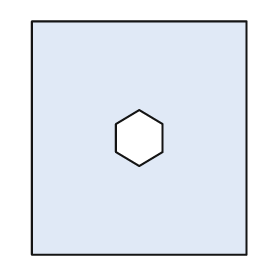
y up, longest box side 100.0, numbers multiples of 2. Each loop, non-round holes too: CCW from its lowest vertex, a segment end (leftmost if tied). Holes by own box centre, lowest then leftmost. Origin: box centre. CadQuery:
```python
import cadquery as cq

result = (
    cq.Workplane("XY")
    .moveTo(-46.0, -50.0)
    .lineTo(46.0, -50.0)
    .lineTo(46.0, 50.0)
    .lineTo(-46.0, 50.0)
    .close()
    .moveTo(0.0, -12.0)
    .lineTo(10.0, -6.0)
    .lineTo(10.0, 6.0)
    .lineTo(0.0, 12.0)
    .lineTo(-10.0, 6.0)
    .lineTo(-10.0, -6.0)
    .close()
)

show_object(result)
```